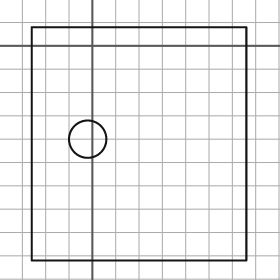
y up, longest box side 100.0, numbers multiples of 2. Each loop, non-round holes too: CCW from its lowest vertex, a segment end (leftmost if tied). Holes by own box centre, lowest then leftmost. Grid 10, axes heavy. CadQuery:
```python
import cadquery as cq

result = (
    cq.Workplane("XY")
    .moveTo(-26.0, -92.0)
    .lineTo(66.0, -92.0)
    .lineTo(66.0, 8.0)
    .lineTo(-26.0, 8.0)
    .close()
    .moveTo(-2.0, -40.0)
    .circle(8.0)
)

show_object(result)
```